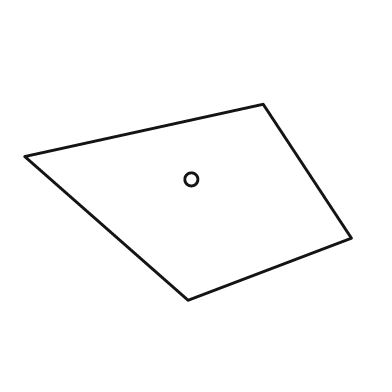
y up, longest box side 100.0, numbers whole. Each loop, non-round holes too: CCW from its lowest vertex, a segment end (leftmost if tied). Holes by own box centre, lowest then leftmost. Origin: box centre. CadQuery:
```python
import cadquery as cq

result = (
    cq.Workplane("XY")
    .moveTo(0.0, -30.0)
    .lineTo(50.0, -11.0)
    .lineTo(23.0, 30.0)
    .lineTo(-50.0, 14.0)
    .close()
    .moveTo(1.0, 7.0)
    .circle(2.0)
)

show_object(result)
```